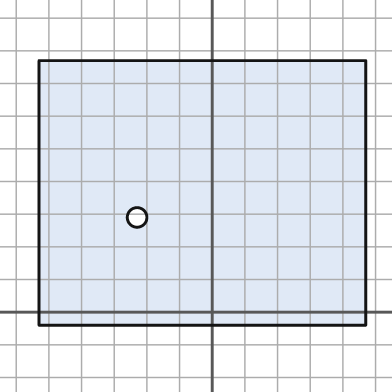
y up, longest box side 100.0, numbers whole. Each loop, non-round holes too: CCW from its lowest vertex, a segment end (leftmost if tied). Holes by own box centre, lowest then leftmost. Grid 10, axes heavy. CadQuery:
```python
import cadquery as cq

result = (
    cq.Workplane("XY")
    .moveTo(-53.0, -4.0)
    .lineTo(47.0, -4.0)
    .lineTo(47.0, 77.0)
    .lineTo(-53.0, 77.0)
    .close()
    .moveTo(-23.0, 29.0)
    .circle(3.0)
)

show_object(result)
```